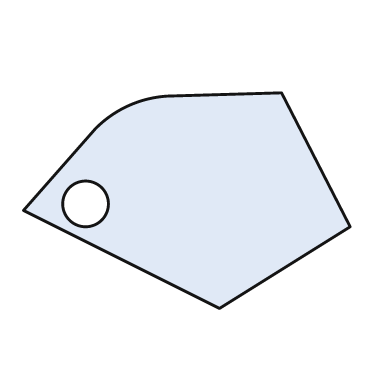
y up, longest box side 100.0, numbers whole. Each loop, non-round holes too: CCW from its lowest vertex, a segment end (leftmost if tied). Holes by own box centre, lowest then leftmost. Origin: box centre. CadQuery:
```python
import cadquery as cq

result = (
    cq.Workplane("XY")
    .moveTo(10.0, -33.0)
    .lineTo(50.0, -8.0)
    .lineTo(29.0, 33.0)
    .lineTo(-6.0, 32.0)
    .threePointArc((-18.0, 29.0), (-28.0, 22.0))
    .lineTo(-50.0, -3.0)
    .close()
    .moveTo(-31.0, -1.0)
    .circle(7.0)
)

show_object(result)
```